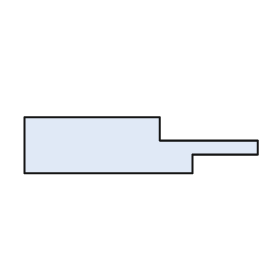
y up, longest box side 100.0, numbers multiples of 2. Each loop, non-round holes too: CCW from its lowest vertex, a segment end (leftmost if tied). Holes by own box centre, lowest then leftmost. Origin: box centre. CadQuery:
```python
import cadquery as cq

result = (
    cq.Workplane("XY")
    .moveTo(-50.0, -12.0)
    .lineTo(22.0, -12.0)
    .lineTo(22.0, -4.0)
    .lineTo(50.0, -4.0)
    .lineTo(50.0, 2.0)
    .lineTo(8.0, 2.0)
    .lineTo(8.0, 12.0)
    .lineTo(-50.0, 12.0)
    .close()
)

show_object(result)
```